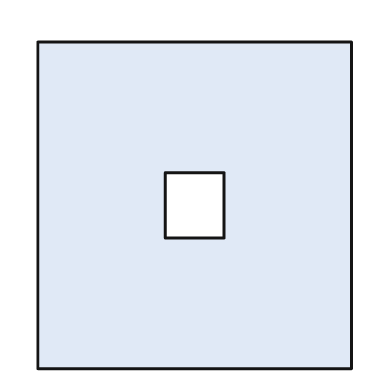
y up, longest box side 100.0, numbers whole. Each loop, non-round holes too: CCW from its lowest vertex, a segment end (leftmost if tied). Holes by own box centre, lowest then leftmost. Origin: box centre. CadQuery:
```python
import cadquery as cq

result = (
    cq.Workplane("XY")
    .moveTo(-48.0, -50.0)
    .lineTo(48.0, -50.0)
    .lineTo(48.0, 50.0)
    .lineTo(-48.0, 50.0)
    .close()
    .moveTo(-9.0, -10.0)
    .lineTo(9.0, -10.0)
    .lineTo(9.0, 10.0)
    .lineTo(-9.0, 10.0)
    .close()
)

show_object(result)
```